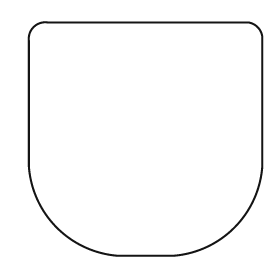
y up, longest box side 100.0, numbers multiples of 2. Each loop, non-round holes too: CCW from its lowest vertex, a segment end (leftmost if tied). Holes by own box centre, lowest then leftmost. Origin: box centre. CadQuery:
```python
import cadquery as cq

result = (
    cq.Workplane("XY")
    .moveTo(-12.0, -50.0)
    .lineTo(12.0, -50.0)
    .threePointArc((38.0, -38.0), (50.0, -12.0))
    .lineTo(50.0, 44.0)
    .threePointArc((48.0, 48.0), (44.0, 50.0))
    .lineTo(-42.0, 50.0)
    .threePointArc((-48.0, 48.0), (-50.0, 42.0))
    .lineTo(-50.0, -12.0)
    .threePointArc((-38.0, -38.0), (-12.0, -50.0))
    .close()
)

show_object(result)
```